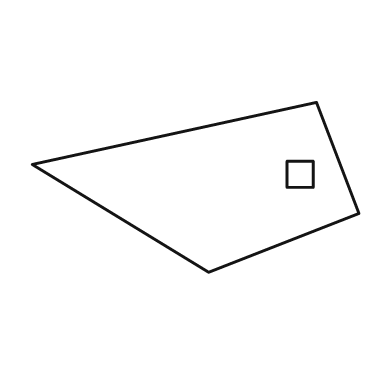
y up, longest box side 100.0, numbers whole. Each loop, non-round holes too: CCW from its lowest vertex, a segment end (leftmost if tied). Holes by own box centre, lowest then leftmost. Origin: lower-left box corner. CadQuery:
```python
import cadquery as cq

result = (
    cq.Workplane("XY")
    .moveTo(54.0, 0.0)
    .lineTo(100.0, 18.0)
    .lineTo(87.0, 52.0)
    .lineTo(0.0, 33.0)
    .close()
    .moveTo(78.0, 26.0)
    .lineTo(86.0, 26.0)
    .lineTo(86.0, 34.0)
    .lineTo(78.0, 34.0)
    .close()
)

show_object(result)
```